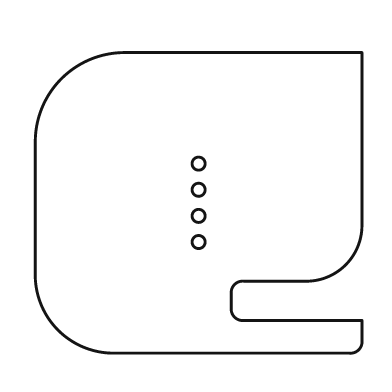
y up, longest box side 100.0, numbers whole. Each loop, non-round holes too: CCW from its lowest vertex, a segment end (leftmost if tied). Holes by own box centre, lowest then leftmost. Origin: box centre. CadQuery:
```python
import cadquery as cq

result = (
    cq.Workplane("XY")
    .moveTo(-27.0, -46.0)
    .lineTo(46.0, -46.0)
    .threePointArc((49.0, -45.0), (50.0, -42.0))
    .lineTo(50.0, -36.0)
    .lineTo(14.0, -36.0)
    .threePointArc((11.0, -35.0), (10.0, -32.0))
    .lineTo(10.0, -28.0)
    .threePointArc((11.0, -25.0), (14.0, -24.0))
    .lineTo(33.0, -24.0)
    .threePointArc((45.0, -19.0), (50.0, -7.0))
    .lineTo(50.0, 46.0)
    .lineTo(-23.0, 46.0)
    .threePointArc((-42.0, 38.0), (-50.0, 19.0))
    .lineTo(-50.0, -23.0)
    .threePointArc((-43.0, -39.0), (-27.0, -46.0))
    .close()
    .moveTo(0.0, -12.0)
    .circle(2.0)
    .moveTo(0.0, -4.0)
    .circle(2.0)
    .moveTo(0.0, 4.0)
    .circle(2.0)
    .moveTo(0.0, 12.0)
    .circle(2.0)
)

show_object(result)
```